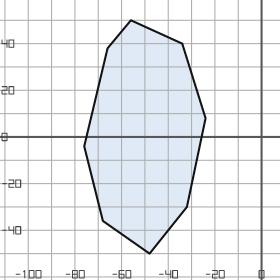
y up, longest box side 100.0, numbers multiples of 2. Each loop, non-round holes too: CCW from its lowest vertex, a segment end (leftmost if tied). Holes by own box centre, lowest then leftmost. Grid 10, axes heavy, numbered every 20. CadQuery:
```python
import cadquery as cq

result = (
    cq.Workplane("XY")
    .moveTo(-48.0, -50.0)
    .lineTo(-32.0, -30.0)
    .lineTo(-24.0, 8.0)
    .lineTo(-34.0, 40.0)
    .lineTo(-56.0, 50.0)
    .lineTo(-66.0, 38.0)
    .lineTo(-76.0, -4.0)
    .lineTo(-68.0, -36.0)
    .close()
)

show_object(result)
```